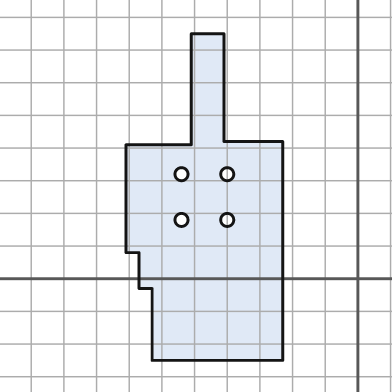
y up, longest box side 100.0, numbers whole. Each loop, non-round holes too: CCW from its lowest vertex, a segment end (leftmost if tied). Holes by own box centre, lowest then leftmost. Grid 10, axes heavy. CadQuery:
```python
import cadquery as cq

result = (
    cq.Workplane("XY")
    .moveTo(-63.0, -25.0)
    .lineTo(-23.0, -25.0)
    .lineTo(-23.0, 42.0)
    .lineTo(-41.0, 42.0)
    .lineTo(-41.0, 75.0)
    .lineTo(-51.0, 75.0)
    .lineTo(-51.0, 41.0)
    .lineTo(-71.0, 41.0)
    .lineTo(-71.0, 8.0)
    .lineTo(-67.0, 8.0)
    .lineTo(-67.0, -3.0)
    .lineTo(-63.0, -3.0)
    .close()
    .moveTo(-54.0, 18.0)
    .circle(2.0)
    .moveTo(-40.0, 18.0)
    .circle(2.0)
    .moveTo(-54.0, 32.0)
    .circle(2.0)
    .moveTo(-40.0, 32.0)
    .circle(2.0)
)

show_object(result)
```